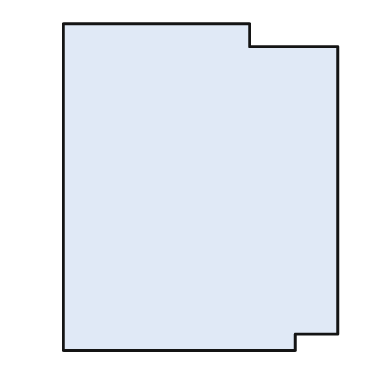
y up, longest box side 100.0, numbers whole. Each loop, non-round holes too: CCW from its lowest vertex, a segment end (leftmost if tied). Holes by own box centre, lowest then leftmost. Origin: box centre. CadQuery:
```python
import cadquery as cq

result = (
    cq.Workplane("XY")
    .moveTo(-42.0, -50.0)
    .lineTo(29.0, -50.0)
    .lineTo(29.0, -45.0)
    .lineTo(42.0, -45.0)
    .lineTo(42.0, 43.0)
    .lineTo(15.0, 43.0)
    .lineTo(15.0, 50.0)
    .lineTo(-42.0, 50.0)
    .close()
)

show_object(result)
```